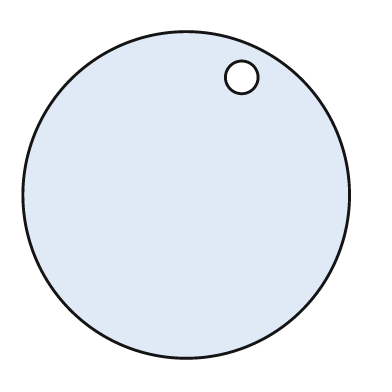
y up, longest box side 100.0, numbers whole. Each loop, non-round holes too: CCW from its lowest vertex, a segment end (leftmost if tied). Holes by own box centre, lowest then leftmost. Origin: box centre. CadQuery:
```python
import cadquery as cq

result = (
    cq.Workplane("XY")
    .moveTo(0.0, 0.0)
    .circle(50.0)
    .moveTo(17.0, 36.0)
    .circle(5.0)
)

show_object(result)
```